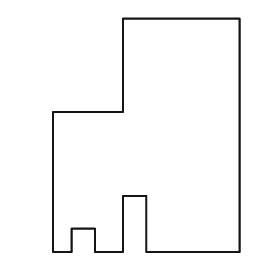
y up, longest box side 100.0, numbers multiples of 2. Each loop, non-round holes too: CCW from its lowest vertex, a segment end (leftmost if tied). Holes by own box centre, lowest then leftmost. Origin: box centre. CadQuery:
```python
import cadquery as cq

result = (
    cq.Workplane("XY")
    .moveTo(-40.0, -50.0)
    .lineTo(-32.0, -50.0)
    .lineTo(-32.0, -40.0)
    .lineTo(-22.0, -40.0)
    .lineTo(-22.0, -50.0)
    .lineTo(-10.0, -50.0)
    .lineTo(-10.0, -26.0)
    .lineTo(0.0, -26.0)
    .lineTo(0.0, -50.0)
    .lineTo(40.0, -50.0)
    .lineTo(40.0, 50.0)
    .lineTo(-10.0, 50.0)
    .lineTo(-10.0, 10.0)
    .lineTo(-40.0, 10.0)
    .close()
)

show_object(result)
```